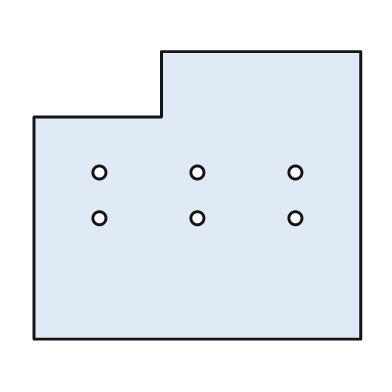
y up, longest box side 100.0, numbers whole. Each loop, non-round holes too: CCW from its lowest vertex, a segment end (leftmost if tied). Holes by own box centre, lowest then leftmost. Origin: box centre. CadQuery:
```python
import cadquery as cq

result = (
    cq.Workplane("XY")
    .moveTo(-50.0, -44.0)
    .lineTo(50.0, -44.0)
    .lineTo(50.0, 44.0)
    .lineTo(-11.0, 44.0)
    .lineTo(-11.0, 24.0)
    .lineTo(-50.0, 24.0)
    .close()
    .moveTo(-30.0, -7.0)
    .circle(2.0)
    .moveTo(0.0, -7.0)
    .circle(2.0)
    .moveTo(30.0, -7.0)
    .circle(2.0)
    .moveTo(-30.0, 7.0)
    .circle(2.0)
    .moveTo(0.0, 7.0)
    .circle(2.0)
    .moveTo(30.0, 7.0)
    .circle(2.0)
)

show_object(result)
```